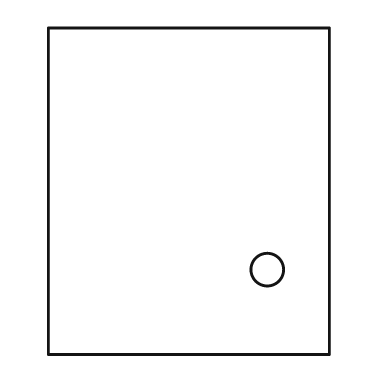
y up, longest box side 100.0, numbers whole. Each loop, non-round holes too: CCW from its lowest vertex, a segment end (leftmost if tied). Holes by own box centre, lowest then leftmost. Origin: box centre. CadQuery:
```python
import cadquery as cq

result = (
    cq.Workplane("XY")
    .moveTo(-43.0, -50.0)
    .lineTo(43.0, -50.0)
    .lineTo(43.0, 50.0)
    .lineTo(-43.0, 50.0)
    .close()
    .moveTo(24.0, -24.0)
    .circle(5.0)
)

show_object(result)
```